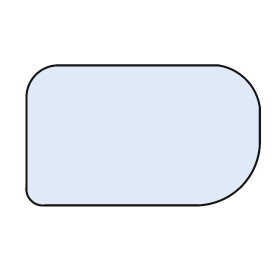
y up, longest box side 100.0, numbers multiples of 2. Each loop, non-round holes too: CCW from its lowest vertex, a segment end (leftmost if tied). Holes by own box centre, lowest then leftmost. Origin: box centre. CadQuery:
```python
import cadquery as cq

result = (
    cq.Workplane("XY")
    .moveTo(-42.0, -30.0)
    .lineTo(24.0, -30.0)
    .threePointArc((42.0, -22.0), (50.0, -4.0))
    .lineTo(50.0, 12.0)
    .threePointArc((44.0, 24.0), (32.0, 30.0))
    .lineTo(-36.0, 30.0)
    .threePointArc((-46.0, 26.0), (-50.0, 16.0))
    .lineTo(-50.0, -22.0)
    .threePointArc((-48.0, -28.0), (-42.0, -30.0))
    .close()
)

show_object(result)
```